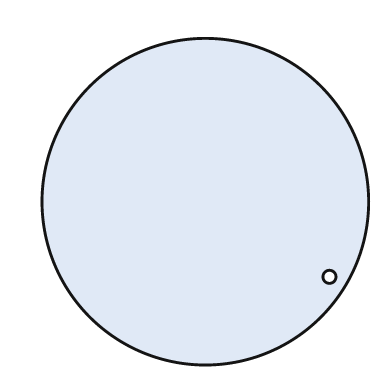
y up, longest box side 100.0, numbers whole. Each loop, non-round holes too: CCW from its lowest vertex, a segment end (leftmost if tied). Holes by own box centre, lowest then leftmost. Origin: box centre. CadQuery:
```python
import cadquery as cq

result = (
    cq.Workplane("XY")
    .moveTo(0.0, 0.0)
    .circle(50.0)
    .moveTo(38.0, -23.0)
    .circle(2.0)
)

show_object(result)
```